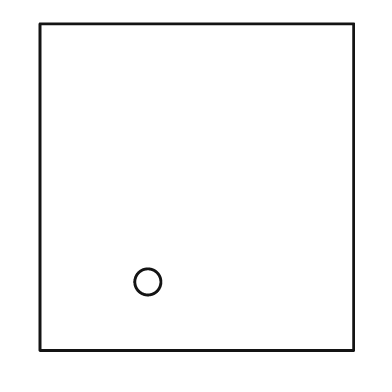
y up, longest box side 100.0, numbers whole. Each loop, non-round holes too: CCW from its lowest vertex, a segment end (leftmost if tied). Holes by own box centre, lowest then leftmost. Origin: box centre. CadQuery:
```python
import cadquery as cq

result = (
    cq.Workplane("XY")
    .moveTo(-48.0, -50.0)
    .lineTo(48.0, -50.0)
    .lineTo(48.0, 50.0)
    .lineTo(-48.0, 50.0)
    .close()
    .moveTo(-15.0, -29.0)
    .circle(4.0)
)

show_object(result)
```